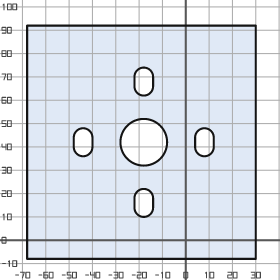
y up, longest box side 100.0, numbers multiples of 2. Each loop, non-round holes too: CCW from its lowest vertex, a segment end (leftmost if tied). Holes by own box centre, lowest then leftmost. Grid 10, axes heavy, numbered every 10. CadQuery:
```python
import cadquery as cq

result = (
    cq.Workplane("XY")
    .moveTo(-68.0, -8.0)
    .lineTo(30.0, -8.0)
    .lineTo(30.0, 92.0)
    .lineTo(-68.0, 92.0)
    .close()
    .moveTo(-22.0, 14.0)
    .threePointArc((-18.0, 10.0), (-14.0, 14.0))
    .lineTo(-14.0, 18.0)
    .threePointArc((-18.0, 22.0), (-22.0, 18.0))
    .close()
    .moveTo(-48.0, 40.0)
    .threePointArc((-44.0, 36.0), (-40.0, 40.0))
    .lineTo(-40.0, 44.0)
    .threePointArc((-44.0, 48.0), (-48.0, 44.0))
    .close()
    .moveTo(-18.0, 42.0)
    .circle(10.0)
    .moveTo(4.0, 40.0)
    .threePointArc((8.0, 36.0), (12.0, 40.0))
    .lineTo(12.0, 44.0)
    .threePointArc((8.0, 48.0), (4.0, 44.0))
    .close()
    .moveTo(-22.0, 66.0)
    .threePointArc((-18.0, 62.0), (-14.0, 66.0))
    .lineTo(-14.0, 70.0)
    .threePointArc((-18.0, 74.0), (-22.0, 70.0))
    .close()
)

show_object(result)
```